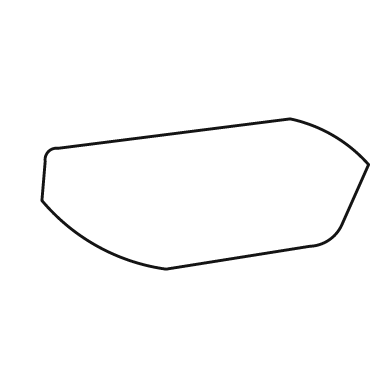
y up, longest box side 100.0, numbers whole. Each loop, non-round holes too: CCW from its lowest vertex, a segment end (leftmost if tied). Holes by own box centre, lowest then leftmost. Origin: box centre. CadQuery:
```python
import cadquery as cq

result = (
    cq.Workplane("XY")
    .moveTo(-12.0, -23.0)
    .lineTo(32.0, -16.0)
    .threePointArc((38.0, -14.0), (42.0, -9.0))
    .lineTo(50.0, 9.0)
    .threePointArc((39.0, 18.0), (26.0, 23.0))
    .lineTo(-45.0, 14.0)
    .threePointArc((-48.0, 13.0), (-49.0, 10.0))
    .lineTo(-50.0, -2.0)
    .threePointArc((-33.0, -16.0), (-12.0, -23.0))
    .close()
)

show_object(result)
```